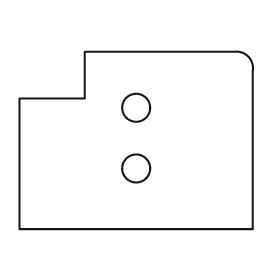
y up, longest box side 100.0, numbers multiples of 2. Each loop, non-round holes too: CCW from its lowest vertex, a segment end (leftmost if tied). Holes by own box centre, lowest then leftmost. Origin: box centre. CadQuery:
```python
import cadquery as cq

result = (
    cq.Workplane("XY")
    .moveTo(-50.0, -38.0)
    .lineTo(50.0, -38.0)
    .lineTo(50.0, 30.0)
    .threePointArc((48.0, 36.0), (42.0, 38.0))
    .lineTo(-22.0, 38.0)
    .lineTo(-22.0, 18.0)
    .lineTo(-50.0, 18.0)
    .close()
    .moveTo(0.0, -12.0)
    .circle(6.0)
    .moveTo(0.0, 14.0)
    .circle(6.0)
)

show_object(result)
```